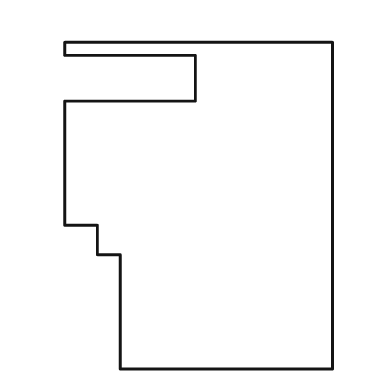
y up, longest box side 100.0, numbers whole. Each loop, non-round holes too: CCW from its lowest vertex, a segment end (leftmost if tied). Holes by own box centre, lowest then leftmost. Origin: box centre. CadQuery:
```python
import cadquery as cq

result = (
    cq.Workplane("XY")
    .moveTo(-24.0, -50.0)
    .lineTo(41.0, -50.0)
    .lineTo(41.0, 50.0)
    .lineTo(-41.0, 50.0)
    .lineTo(-41.0, 46.0)
    .lineTo(-1.0, 46.0)
    .lineTo(-1.0, 32.0)
    .lineTo(-41.0, 32.0)
    .lineTo(-41.0, -6.0)
    .lineTo(-31.0, -6.0)
    .lineTo(-31.0, -15.0)
    .lineTo(-24.0, -15.0)
    .close()
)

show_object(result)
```